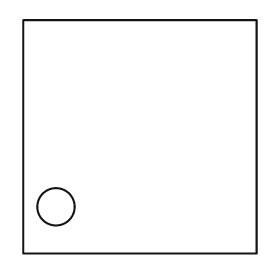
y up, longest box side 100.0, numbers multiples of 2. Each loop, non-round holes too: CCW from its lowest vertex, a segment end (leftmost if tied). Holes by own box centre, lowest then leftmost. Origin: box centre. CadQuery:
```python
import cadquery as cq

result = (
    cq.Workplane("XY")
    .moveTo(-50.0, -50.0)
    .lineTo(50.0, -50.0)
    .lineTo(50.0, 50.0)
    .lineTo(-50.0, 50.0)
    .close()
    .moveTo(-36.0, -30.0)
    .circle(8.0)
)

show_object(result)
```